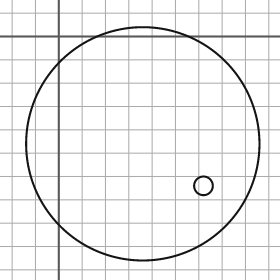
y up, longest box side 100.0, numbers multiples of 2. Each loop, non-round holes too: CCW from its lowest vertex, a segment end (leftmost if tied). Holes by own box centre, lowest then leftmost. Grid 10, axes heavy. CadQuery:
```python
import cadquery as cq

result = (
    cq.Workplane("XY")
    .moveTo(36.0, -46.0)
    .circle(50.0)
    .moveTo(62.0, -64.0)
    .circle(4.0)
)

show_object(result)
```